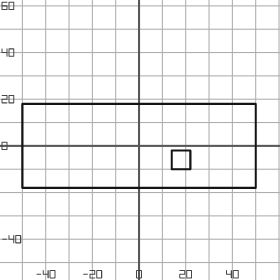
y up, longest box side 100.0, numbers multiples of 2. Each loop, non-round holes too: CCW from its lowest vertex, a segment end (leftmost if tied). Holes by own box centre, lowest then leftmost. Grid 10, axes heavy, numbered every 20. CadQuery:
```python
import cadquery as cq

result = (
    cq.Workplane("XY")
    .moveTo(-50.0, -18.0)
    .lineTo(50.0, -18.0)
    .lineTo(50.0, 18.0)
    .lineTo(-50.0, 18.0)
    .close()
    .moveTo(14.0, -10.0)
    .lineTo(22.0, -10.0)
    .lineTo(22.0, -2.0)
    .lineTo(14.0, -2.0)
    .close()
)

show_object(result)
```